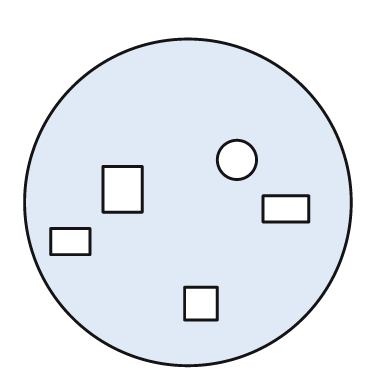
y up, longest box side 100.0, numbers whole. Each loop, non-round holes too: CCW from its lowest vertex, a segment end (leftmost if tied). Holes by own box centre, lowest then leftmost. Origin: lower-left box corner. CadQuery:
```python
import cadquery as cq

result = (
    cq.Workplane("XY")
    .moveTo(50.0, 50.0)
    .circle(50.0)
    .moveTo(49.0, 14.0)
    .lineTo(59.0, 14.0)
    .lineTo(59.0, 24.0)
    .lineTo(49.0, 24.0)
    .close()
    .moveTo(8.0, 34.0)
    .lineTo(20.0, 34.0)
    .lineTo(20.0, 42.0)
    .lineTo(8.0, 42.0)
    .close()
    .moveTo(73.0, 44.0)
    .lineTo(87.0, 44.0)
    .lineTo(87.0, 52.0)
    .lineTo(73.0, 52.0)
    .close()
    .moveTo(24.0, 47.0)
    .lineTo(36.0, 47.0)
    .lineTo(36.0, 61.0)
    .lineTo(24.0, 61.0)
    .close()
    .moveTo(65.0, 63.0)
    .circle(6.0)
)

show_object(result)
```